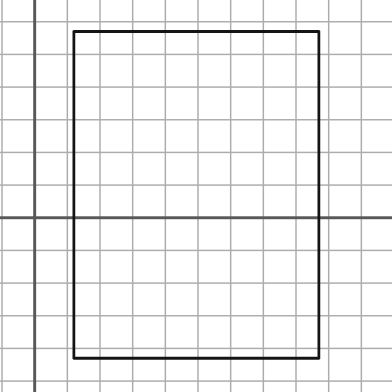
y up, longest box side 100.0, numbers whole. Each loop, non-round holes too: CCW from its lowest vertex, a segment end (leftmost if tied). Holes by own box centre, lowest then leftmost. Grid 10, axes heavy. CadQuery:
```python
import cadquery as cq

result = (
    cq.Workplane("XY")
    .moveTo(12.0, -43.0)
    .lineTo(87.0, -43.0)
    .lineTo(87.0, 57.0)
    .lineTo(12.0, 57.0)
    .close()
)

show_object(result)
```